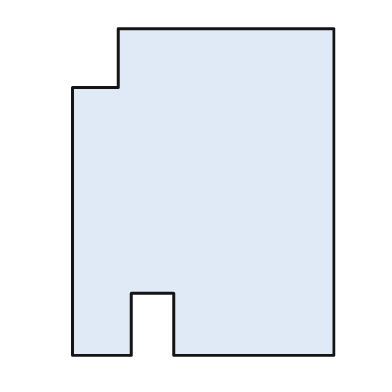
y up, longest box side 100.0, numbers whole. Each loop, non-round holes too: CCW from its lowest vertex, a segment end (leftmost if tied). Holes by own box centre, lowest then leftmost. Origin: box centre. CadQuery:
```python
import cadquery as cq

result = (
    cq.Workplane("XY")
    .moveTo(-40.0, -50.0)
    .lineTo(-22.0, -50.0)
    .lineTo(-22.0, -31.0)
    .lineTo(-9.0, -31.0)
    .lineTo(-9.0, -50.0)
    .lineTo(40.0, -50.0)
    .lineTo(40.0, 50.0)
    .lineTo(-26.0, 50.0)
    .lineTo(-26.0, 32.0)
    .lineTo(-40.0, 32.0)
    .close()
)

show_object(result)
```